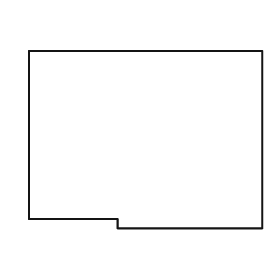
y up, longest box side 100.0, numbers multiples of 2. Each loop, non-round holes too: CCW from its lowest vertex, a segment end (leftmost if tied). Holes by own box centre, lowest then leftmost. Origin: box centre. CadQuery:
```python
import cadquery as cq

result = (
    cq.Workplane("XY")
    .moveTo(-12.0, -38.0)
    .lineTo(50.0, -38.0)
    .lineTo(50.0, 38.0)
    .lineTo(-50.0, 38.0)
    .lineTo(-50.0, -34.0)
    .lineTo(-12.0, -34.0)
    .close()
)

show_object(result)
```